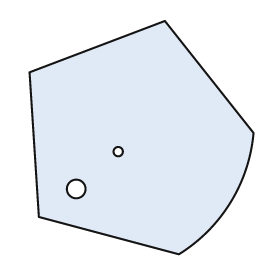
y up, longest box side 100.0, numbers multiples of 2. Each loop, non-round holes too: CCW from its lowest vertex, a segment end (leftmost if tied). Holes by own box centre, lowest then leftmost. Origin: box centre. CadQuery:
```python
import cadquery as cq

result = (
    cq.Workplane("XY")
    .moveTo(16.0, -50.0)
    .threePointArc((38.0, -28.0), (48.0, 2.0))
    .lineTo(10.0, 50.0)
    .lineTo(-48.0, 28.0)
    .lineTo(-44.0, -34.0)
    .close()
    .moveTo(-28.0, -22.0)
    .circle(4.0)
    .moveTo(-10.0, -6.0)
    .circle(2.0)
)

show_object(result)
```